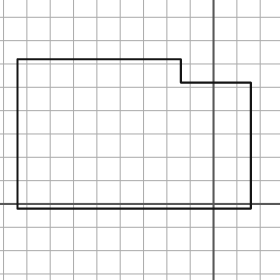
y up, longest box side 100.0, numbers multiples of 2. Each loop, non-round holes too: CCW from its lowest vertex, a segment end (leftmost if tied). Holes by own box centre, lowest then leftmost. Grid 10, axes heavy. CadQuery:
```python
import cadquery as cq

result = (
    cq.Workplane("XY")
    .moveTo(-84.0, -2.0)
    .lineTo(16.0, -2.0)
    .lineTo(16.0, 52.0)
    .lineTo(-14.0, 52.0)
    .lineTo(-14.0, 62.0)
    .lineTo(-84.0, 62.0)
    .close()
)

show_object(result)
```